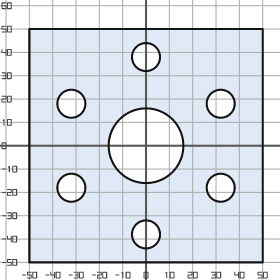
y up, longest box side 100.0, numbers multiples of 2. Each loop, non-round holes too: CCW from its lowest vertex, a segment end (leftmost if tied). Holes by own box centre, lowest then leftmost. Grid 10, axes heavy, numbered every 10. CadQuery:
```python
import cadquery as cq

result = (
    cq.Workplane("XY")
    .moveTo(-50.0, -50.0)
    .lineTo(50.0, -50.0)
    .lineTo(50.0, 50.0)
    .lineTo(-50.0, 50.0)
    .close()
    .moveTo(0.0, -38.0)
    .circle(6.0)
    .moveTo(-32.0, -18.0)
    .circle(6.0)
    .moveTo(32.0, -18.0)
    .circle(6.0)
    .moveTo(0.0, 0.0)
    .circle(16.0)
    .moveTo(-32.0, 18.0)
    .circle(6.0)
    .moveTo(32.0, 18.0)
    .circle(6.0)
    .moveTo(0.0, 38.0)
    .circle(6.0)
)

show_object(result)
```